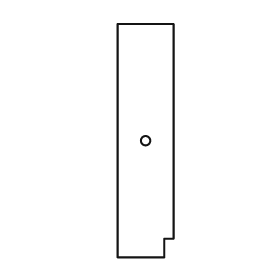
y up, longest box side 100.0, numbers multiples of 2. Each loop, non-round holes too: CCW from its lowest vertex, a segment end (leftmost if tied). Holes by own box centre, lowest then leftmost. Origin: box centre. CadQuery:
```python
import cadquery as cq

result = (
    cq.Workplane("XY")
    .moveTo(-12.0, -50.0)
    .lineTo(8.0, -50.0)
    .lineTo(8.0, -42.0)
    .lineTo(12.0, -42.0)
    .lineTo(12.0, 50.0)
    .lineTo(-12.0, 50.0)
    .close()
    .moveTo(0.0, 0.0)
    .circle(2.0)
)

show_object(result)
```